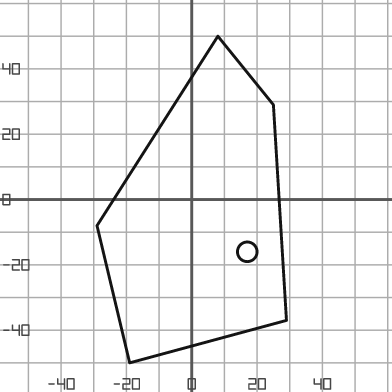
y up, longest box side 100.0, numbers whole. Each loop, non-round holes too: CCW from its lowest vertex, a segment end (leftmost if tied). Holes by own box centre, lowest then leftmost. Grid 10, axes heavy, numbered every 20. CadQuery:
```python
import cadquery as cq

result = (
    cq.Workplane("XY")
    .moveTo(-19.0, -50.0)
    .lineTo(29.0, -37.0)
    .lineTo(25.0, 29.0)
    .lineTo(8.0, 50.0)
    .lineTo(-29.0, -8.0)
    .close()
    .moveTo(17.0, -16.0)
    .circle(3.0)
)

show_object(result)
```